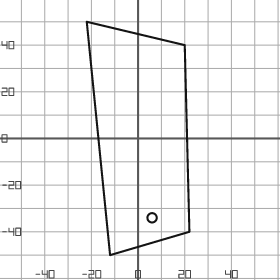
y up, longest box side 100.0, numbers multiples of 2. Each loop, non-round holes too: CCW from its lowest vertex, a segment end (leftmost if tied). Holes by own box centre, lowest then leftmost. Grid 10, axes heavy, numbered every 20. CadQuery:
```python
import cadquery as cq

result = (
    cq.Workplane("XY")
    .moveTo(-12.0, -50.0)
    .lineTo(22.0, -40.0)
    .lineTo(20.0, 40.0)
    .lineTo(-22.0, 50.0)
    .close()
    .moveTo(6.0, -34.0)
    .circle(2.0)
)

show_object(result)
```